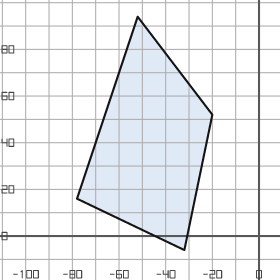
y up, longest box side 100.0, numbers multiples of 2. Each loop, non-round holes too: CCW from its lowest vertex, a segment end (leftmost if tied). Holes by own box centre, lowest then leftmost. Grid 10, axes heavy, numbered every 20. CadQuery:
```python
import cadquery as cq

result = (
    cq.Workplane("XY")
    .moveTo(-32.0, -6.0)
    .lineTo(-20.0, 52.0)
    .lineTo(-52.0, 94.0)
    .lineTo(-78.0, 16.0)
    .close()
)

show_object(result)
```